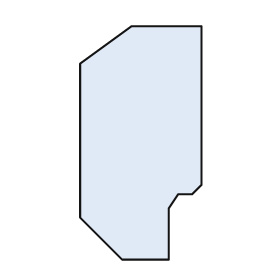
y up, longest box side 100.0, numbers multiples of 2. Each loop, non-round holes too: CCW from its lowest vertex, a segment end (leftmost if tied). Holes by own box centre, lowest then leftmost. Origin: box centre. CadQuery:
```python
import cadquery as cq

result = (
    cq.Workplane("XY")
    .moveTo(-8.0, -50.0)
    .lineTo(12.0, -50.0)
    .lineTo(12.0, -28.0)
    .lineTo(16.0, -22.0)
    .lineTo(22.0, -22.0)
    .lineTo(26.0, -18.0)
    .lineTo(26.0, 50.0)
    .lineTo(-4.0, 50.0)
    .lineTo(-26.0, 34.0)
    .lineTo(-26.0, -32.0)
    .close()
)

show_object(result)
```